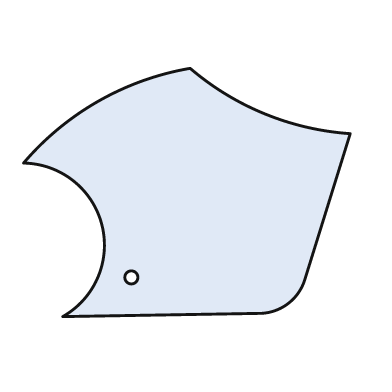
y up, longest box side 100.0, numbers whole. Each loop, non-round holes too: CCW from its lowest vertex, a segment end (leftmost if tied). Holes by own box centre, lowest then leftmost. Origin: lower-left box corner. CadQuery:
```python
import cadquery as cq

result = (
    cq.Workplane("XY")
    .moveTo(12.0, 0.0)
    .lineTo(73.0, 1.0)
    .threePointArc((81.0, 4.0), (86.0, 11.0))
    .lineTo(100.0, 56.0)
    .threePointArc((74.0, 62.0), (51.0, 76.0))
    .threePointArc((23.0, 66.0), (0.0, 47.0))
    .threePointArc((24.0, 28.0), (12.0, 0.0))
    .close()
    .moveTo(33.0, 12.0)
    .circle(2.0)
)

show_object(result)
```